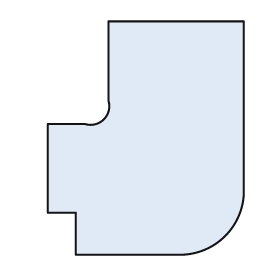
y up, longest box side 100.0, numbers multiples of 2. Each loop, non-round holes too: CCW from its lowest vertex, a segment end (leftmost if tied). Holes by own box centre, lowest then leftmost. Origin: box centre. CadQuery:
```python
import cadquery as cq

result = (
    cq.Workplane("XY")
    .moveTo(-30.0, -50.0)
    .lineTo(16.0, -50.0)
    .threePointArc((34.0, -42.0), (42.0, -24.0))
    .lineTo(42.0, 50.0)
    .lineTo(-16.0, 50.0)
    .lineTo(-16.0, 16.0)
    .threePointArc((-18.0, 8.0), (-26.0, 6.0))
    .lineTo(-42.0, 6.0)
    .lineTo(-42.0, -32.0)
    .lineTo(-30.0, -32.0)
    .close()
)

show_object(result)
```